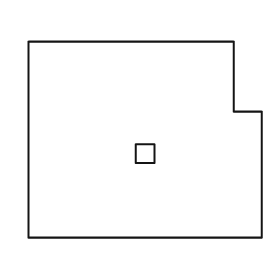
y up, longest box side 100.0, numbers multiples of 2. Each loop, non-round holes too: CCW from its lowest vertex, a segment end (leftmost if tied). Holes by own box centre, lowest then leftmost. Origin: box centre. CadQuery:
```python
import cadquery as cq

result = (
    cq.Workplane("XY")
    .moveTo(-50.0, -42.0)
    .lineTo(50.0, -42.0)
    .lineTo(50.0, 12.0)
    .lineTo(38.0, 12.0)
    .lineTo(38.0, 42.0)
    .lineTo(-50.0, 42.0)
    .close()
    .moveTo(-4.0, -10.0)
    .lineTo(4.0, -10.0)
    .lineTo(4.0, -2.0)
    .lineTo(-4.0, -2.0)
    .close()
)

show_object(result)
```